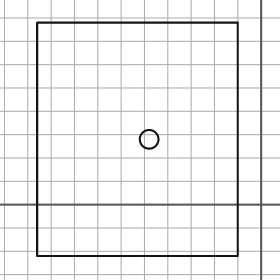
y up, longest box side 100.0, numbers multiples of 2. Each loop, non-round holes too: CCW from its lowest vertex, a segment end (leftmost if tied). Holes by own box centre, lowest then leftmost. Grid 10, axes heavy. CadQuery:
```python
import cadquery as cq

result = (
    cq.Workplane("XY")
    .moveTo(-96.0, -22.0)
    .lineTo(-10.0, -22.0)
    .lineTo(-10.0, 78.0)
    .lineTo(-96.0, 78.0)
    .close()
    .moveTo(-48.0, 28.0)
    .circle(4.0)
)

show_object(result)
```